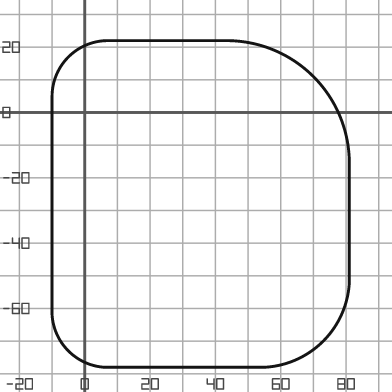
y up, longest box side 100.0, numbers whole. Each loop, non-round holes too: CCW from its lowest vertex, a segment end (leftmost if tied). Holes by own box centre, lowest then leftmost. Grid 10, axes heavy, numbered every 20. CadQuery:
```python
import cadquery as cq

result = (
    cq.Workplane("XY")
    .moveTo(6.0, -78.0)
    .lineTo(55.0, -78.0)
    .threePointArc((73.0, -70.0), (81.0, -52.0))
    .lineTo(81.0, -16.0)
    .threePointArc((70.0, 11.0), (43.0, 22.0))
    .lineTo(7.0, 22.0)
    .threePointArc((-5.0, 17.0), (-10.0, 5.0))
    .lineTo(-10.0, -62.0)
    .threePointArc((-5.0, -73.0), (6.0, -78.0))
    .close()
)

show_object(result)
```